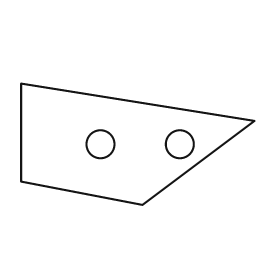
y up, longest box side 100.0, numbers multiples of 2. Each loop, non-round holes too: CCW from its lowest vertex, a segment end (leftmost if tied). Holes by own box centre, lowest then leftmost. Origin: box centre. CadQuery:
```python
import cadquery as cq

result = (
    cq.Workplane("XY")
    .moveTo(2.0, -26.0)
    .lineTo(50.0, 10.0)
    .lineTo(-50.0, 26.0)
    .lineTo(-50.0, -16.0)
    .close()
    .moveTo(-16.0, 0.0)
    .circle(6.0)
    .moveTo(18.0, 0.0)
    .circle(6.0)
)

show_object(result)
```